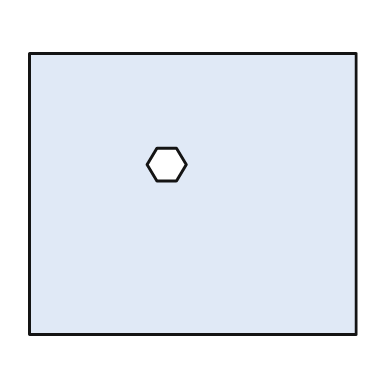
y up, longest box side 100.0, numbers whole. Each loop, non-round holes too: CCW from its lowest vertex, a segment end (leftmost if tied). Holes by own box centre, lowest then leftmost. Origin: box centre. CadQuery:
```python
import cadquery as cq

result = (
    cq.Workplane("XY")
    .moveTo(-50.0, -43.0)
    .lineTo(50.0, -43.0)
    .lineTo(50.0, 43.0)
    .lineTo(-50.0, 43.0)
    .close()
    .moveTo(-11.0, 4.0)
    .lineTo(-5.0, 4.0)
    .lineTo(-2.0, 9.0)
    .lineTo(-5.0, 14.0)
    .lineTo(-11.0, 14.0)
    .lineTo(-14.0, 9.0)
    .close()
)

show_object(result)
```